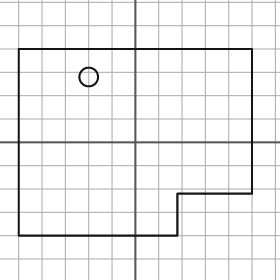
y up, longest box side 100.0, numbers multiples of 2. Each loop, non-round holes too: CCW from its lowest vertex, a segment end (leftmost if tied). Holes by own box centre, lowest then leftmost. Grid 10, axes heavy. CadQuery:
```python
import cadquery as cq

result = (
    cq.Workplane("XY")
    .moveTo(-50.0, -40.0)
    .lineTo(18.0, -40.0)
    .lineTo(18.0, -22.0)
    .lineTo(50.0, -22.0)
    .lineTo(50.0, 40.0)
    .lineTo(-50.0, 40.0)
    .close()
    .moveTo(-20.0, 28.0)
    .circle(4.0)
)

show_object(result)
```